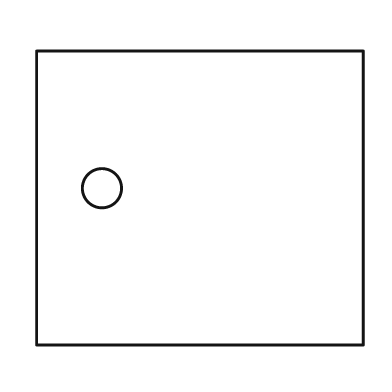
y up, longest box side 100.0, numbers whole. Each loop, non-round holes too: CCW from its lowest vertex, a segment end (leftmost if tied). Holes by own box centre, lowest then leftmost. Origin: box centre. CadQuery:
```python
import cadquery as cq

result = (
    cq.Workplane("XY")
    .moveTo(-50.0, -45.0)
    .lineTo(50.0, -45.0)
    .lineTo(50.0, 45.0)
    .lineTo(-50.0, 45.0)
    .close()
    .moveTo(-30.0, 3.0)
    .circle(6.0)
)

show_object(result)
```